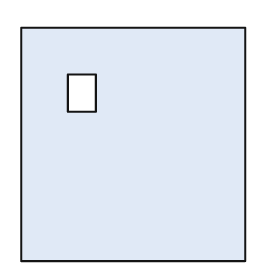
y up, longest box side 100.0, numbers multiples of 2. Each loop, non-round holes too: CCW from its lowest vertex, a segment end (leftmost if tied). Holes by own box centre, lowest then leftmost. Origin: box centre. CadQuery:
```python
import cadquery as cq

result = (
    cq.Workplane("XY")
    .moveTo(-48.0, -50.0)
    .lineTo(48.0, -50.0)
    .lineTo(48.0, 50.0)
    .lineTo(-48.0, 50.0)
    .close()
    .moveTo(-28.0, 14.0)
    .lineTo(-16.0, 14.0)
    .lineTo(-16.0, 30.0)
    .lineTo(-28.0, 30.0)
    .close()
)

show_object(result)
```